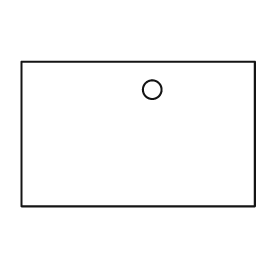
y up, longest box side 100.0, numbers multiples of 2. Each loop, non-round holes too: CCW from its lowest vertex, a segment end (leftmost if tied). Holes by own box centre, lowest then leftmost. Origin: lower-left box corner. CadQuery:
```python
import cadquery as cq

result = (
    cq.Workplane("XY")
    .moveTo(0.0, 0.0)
    .lineTo(100.0, 0.0)
    .lineTo(100.0, 62.0)
    .lineTo(0.0, 62.0)
    .close()
    .moveTo(56.0, 50.0)
    .circle(4.0)
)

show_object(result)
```